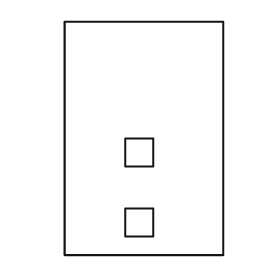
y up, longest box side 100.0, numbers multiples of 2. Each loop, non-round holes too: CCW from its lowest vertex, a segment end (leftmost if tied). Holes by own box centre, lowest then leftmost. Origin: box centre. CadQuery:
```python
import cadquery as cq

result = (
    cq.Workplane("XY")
    .moveTo(-34.0, -50.0)
    .lineTo(34.0, -50.0)
    .lineTo(34.0, 50.0)
    .lineTo(-34.0, 50.0)
    .close()
    .moveTo(-8.0, -42.0)
    .lineTo(4.0, -42.0)
    .lineTo(4.0, -30.0)
    .lineTo(-8.0, -30.0)
    .close()
    .moveTo(-8.0, -12.0)
    .lineTo(4.0, -12.0)
    .lineTo(4.0, 0.0)
    .lineTo(-8.0, 0.0)
    .close()
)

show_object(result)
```